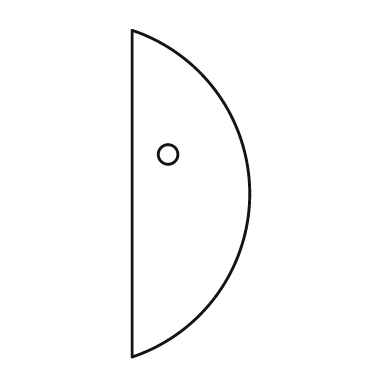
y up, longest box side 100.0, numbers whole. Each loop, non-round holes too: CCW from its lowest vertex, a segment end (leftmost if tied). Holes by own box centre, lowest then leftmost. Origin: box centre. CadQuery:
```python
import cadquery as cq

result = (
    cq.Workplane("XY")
    .moveTo(-18.0, -50.0)
    .threePointArc((18.0, 0.0), (-18.0, 50.0))
    .close()
    .moveTo(-7.0, 12.0)
    .circle(3.0)
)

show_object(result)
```